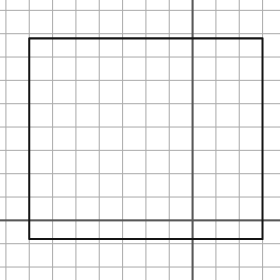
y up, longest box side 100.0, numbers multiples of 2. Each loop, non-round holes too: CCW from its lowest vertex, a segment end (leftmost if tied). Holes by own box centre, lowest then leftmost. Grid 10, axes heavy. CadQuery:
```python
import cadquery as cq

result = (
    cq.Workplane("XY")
    .moveTo(-70.0, -8.0)
    .lineTo(30.0, -8.0)
    .lineTo(30.0, 78.0)
    .lineTo(-70.0, 78.0)
    .close()
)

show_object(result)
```